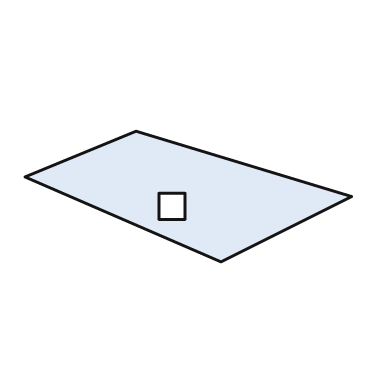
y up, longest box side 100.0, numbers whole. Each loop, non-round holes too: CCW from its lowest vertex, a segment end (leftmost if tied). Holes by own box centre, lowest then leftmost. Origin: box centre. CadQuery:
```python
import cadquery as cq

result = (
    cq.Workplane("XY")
    .moveTo(10.0, -20.0)
    .lineTo(50.0, 0.0)
    .lineTo(-16.0, 20.0)
    .lineTo(-50.0, 6.0)
    .close()
    .moveTo(-9.0, -7.0)
    .lineTo(-1.0, -7.0)
    .lineTo(-1.0, 1.0)
    .lineTo(-9.0, 1.0)
    .close()
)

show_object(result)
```